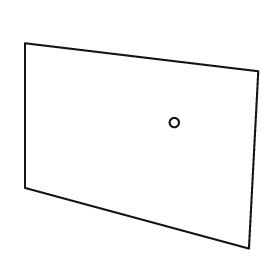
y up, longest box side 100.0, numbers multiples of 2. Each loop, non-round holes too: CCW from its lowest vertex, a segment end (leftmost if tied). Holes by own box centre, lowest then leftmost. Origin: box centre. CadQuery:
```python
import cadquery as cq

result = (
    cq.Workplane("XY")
    .moveTo(46.0, -44.0)
    .lineTo(50.0, 32.0)
    .lineTo(-50.0, 44.0)
    .lineTo(-50.0, -18.0)
    .close()
    .moveTo(14.0, 10.0)
    .circle(2.0)
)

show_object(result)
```